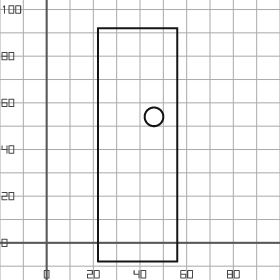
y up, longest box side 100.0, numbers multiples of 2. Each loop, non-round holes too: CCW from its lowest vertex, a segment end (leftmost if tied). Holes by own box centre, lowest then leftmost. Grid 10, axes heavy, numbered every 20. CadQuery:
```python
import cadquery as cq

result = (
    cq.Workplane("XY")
    .moveTo(22.0, -8.0)
    .lineTo(56.0, -8.0)
    .lineTo(56.0, 92.0)
    .lineTo(22.0, 92.0)
    .close()
    .moveTo(46.0, 54.0)
    .circle(4.0)
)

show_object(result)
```